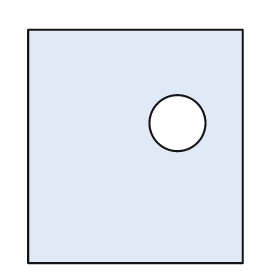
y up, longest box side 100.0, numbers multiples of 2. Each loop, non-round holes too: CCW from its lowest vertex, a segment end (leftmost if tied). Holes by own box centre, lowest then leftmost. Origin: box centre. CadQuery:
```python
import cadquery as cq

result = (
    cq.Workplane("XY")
    .moveTo(-46.0, -50.0)
    .lineTo(46.0, -50.0)
    .lineTo(46.0, 50.0)
    .lineTo(-46.0, 50.0)
    .close()
    .moveTo(18.0, 10.0)
    .circle(12.0)
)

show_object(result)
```